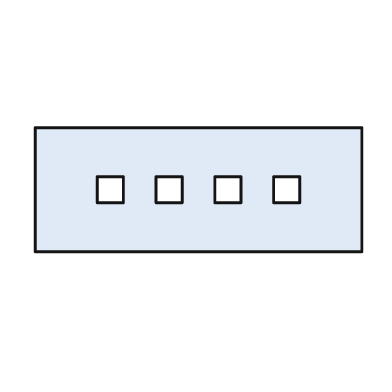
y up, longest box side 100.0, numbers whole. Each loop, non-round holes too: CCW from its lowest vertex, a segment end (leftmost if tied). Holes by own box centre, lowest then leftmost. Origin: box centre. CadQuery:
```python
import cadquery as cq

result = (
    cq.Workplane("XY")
    .moveTo(-50.0, -19.0)
    .lineTo(50.0, -19.0)
    .lineTo(50.0, 19.0)
    .lineTo(-50.0, 19.0)
    .close()
    .moveTo(-31.0, -4.0)
    .lineTo(-23.0, -4.0)
    .lineTo(-23.0, 4.0)
    .lineTo(-31.0, 4.0)
    .close()
    .moveTo(-13.0, -4.0)
    .lineTo(-5.0, -4.0)
    .lineTo(-5.0, 4.0)
    .lineTo(-13.0, 4.0)
    .close()
    .moveTo(5.0, -4.0)
    .lineTo(13.0, -4.0)
    .lineTo(13.0, 4.0)
    .lineTo(5.0, 4.0)
    .close()
    .moveTo(23.0, -4.0)
    .lineTo(31.0, -4.0)
    .lineTo(31.0, 4.0)
    .lineTo(23.0, 4.0)
    .close()
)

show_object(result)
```